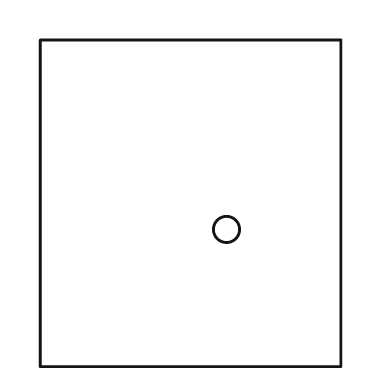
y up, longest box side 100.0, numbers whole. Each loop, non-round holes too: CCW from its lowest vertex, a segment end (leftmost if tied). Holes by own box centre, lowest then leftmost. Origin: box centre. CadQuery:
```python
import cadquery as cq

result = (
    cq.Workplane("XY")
    .moveTo(-46.0, -50.0)
    .lineTo(46.0, -50.0)
    .lineTo(46.0, 50.0)
    .lineTo(-46.0, 50.0)
    .close()
    .moveTo(11.0, -8.0)
    .circle(4.0)
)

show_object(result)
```